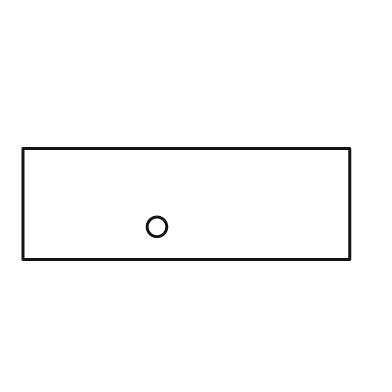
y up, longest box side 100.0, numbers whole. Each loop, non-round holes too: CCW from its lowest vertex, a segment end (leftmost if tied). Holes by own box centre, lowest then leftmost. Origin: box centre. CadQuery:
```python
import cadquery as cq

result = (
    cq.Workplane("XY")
    .moveTo(-50.0, -17.0)
    .lineTo(50.0, -17.0)
    .lineTo(50.0, 17.0)
    .lineTo(-50.0, 17.0)
    .close()
    .moveTo(-9.0, -7.0)
    .circle(3.0)
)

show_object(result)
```